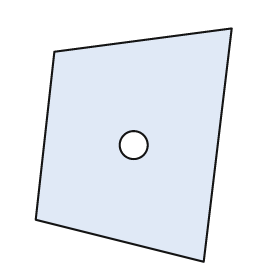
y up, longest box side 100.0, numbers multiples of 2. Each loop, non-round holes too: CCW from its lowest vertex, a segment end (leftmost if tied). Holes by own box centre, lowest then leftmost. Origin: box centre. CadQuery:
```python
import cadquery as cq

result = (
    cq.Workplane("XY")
    .moveTo(30.0, -50.0)
    .lineTo(42.0, 50.0)
    .lineTo(-34.0, 40.0)
    .lineTo(-42.0, -32.0)
    .close()
    .moveTo(0.0, 0.0)
    .circle(6.0)
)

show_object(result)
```